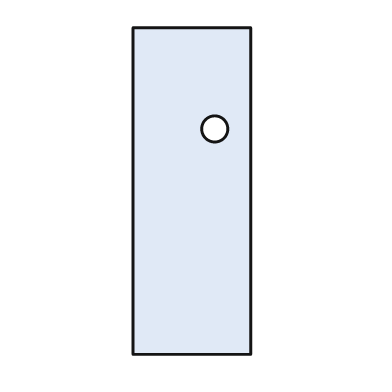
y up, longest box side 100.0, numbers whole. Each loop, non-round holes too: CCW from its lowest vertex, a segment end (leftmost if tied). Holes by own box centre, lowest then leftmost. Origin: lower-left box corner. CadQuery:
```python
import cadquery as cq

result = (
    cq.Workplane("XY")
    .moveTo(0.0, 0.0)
    .lineTo(36.0, 0.0)
    .lineTo(36.0, 100.0)
    .lineTo(0.0, 100.0)
    .close()
    .moveTo(25.0, 69.0)
    .circle(4.0)
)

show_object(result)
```